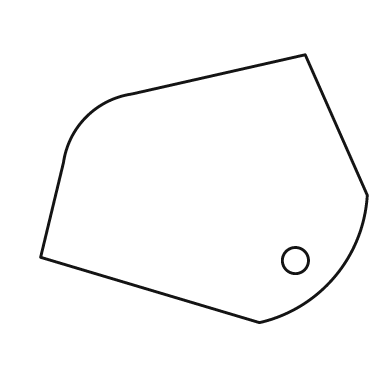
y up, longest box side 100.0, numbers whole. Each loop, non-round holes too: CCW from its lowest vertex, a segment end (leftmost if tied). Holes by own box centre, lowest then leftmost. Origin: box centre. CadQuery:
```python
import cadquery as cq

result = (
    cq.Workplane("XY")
    .moveTo(17.0, -41.0)
    .threePointArc((40.0, -27.0), (50.0, -2.0))
    .lineTo(31.0, 41.0)
    .lineTo(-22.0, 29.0)
    .threePointArc((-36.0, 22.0), (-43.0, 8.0))
    .lineTo(-50.0, -21.0)
    .close()
    .moveTo(28.0, -22.0)
    .circle(4.0)
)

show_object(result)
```